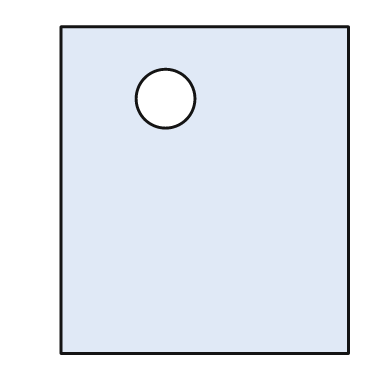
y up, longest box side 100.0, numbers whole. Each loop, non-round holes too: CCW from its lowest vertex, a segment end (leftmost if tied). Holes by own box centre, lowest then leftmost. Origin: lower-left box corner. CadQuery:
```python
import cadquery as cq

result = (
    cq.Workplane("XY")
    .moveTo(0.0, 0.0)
    .lineTo(88.0, 0.0)
    .lineTo(88.0, 100.0)
    .lineTo(0.0, 100.0)
    .close()
    .moveTo(32.0, 78.0)
    .circle(9.0)
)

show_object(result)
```